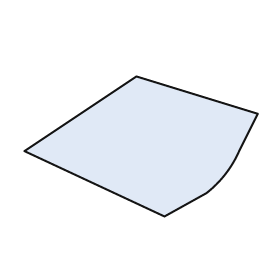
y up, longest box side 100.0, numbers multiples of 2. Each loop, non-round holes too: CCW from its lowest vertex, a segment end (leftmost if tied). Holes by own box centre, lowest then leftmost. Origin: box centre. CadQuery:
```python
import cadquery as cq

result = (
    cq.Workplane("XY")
    .moveTo(10.0, -30.0)
    .lineTo(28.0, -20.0)
    .threePointArc((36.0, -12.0), (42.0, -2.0))
    .lineTo(50.0, 14.0)
    .lineTo(-2.0, 30.0)
    .lineTo(-50.0, -2.0)
    .close()
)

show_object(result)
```